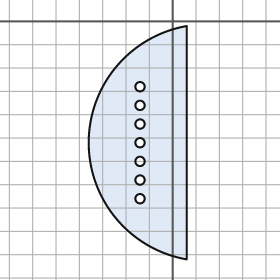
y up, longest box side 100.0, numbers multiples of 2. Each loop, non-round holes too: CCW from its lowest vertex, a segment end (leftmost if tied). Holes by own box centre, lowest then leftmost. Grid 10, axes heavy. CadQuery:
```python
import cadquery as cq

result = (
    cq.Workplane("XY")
    .moveTo(6.0, -102.0)
    .lineTo(6.0, -2.0)
    .threePointArc((-36.0, -52.0), (6.0, -102.0))
    .close()
    .moveTo(-14.0, -76.0)
    .circle(2.0)
    .moveTo(-14.0, -68.0)
    .circle(2.0)
    .moveTo(-14.0, -60.0)
    .circle(2.0)
    .moveTo(-14.0, -52.0)
    .circle(2.0)
    .moveTo(-14.0, -44.0)
    .circle(2.0)
    .moveTo(-14.0, -36.0)
    .circle(2.0)
    .moveTo(-14.0, -28.0)
    .circle(2.0)
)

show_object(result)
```